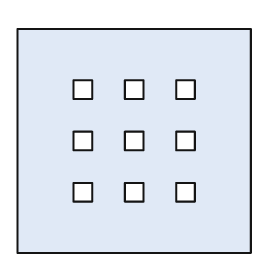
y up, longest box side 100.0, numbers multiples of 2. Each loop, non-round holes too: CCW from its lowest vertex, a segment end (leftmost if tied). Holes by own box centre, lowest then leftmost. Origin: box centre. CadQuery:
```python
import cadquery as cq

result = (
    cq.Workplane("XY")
    .moveTo(-50.0, -48.0)
    .lineTo(50.0, -48.0)
    .lineTo(50.0, 48.0)
    .lineTo(-50.0, 48.0)
    .close()
    .moveTo(-26.0, -26.0)
    .lineTo(-18.0, -26.0)
    .lineTo(-18.0, -18.0)
    .lineTo(-26.0, -18.0)
    .close()
    .moveTo(-4.0, -26.0)
    .lineTo(4.0, -26.0)
    .lineTo(4.0, -18.0)
    .lineTo(-4.0, -18.0)
    .close()
    .moveTo(18.0, -26.0)
    .lineTo(26.0, -26.0)
    .lineTo(26.0, -18.0)
    .lineTo(18.0, -18.0)
    .close()
    .moveTo(-26.0, -4.0)
    .lineTo(-18.0, -4.0)
    .lineTo(-18.0, 4.0)
    .lineTo(-26.0, 4.0)
    .close()
    .moveTo(-4.0, -4.0)
    .lineTo(4.0, -4.0)
    .lineTo(4.0, 4.0)
    .lineTo(-4.0, 4.0)
    .close()
    .moveTo(18.0, -4.0)
    .lineTo(26.0, -4.0)
    .lineTo(26.0, 4.0)
    .lineTo(18.0, 4.0)
    .close()
    .moveTo(-26.0, 18.0)
    .lineTo(-18.0, 18.0)
    .lineTo(-18.0, 26.0)
    .lineTo(-26.0, 26.0)
    .close()
    .moveTo(-4.0, 18.0)
    .lineTo(4.0, 18.0)
    .lineTo(4.0, 26.0)
    .lineTo(-4.0, 26.0)
    .close()
    .moveTo(18.0, 18.0)
    .lineTo(26.0, 18.0)
    .lineTo(26.0, 26.0)
    .lineTo(18.0, 26.0)
    .close()
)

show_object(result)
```